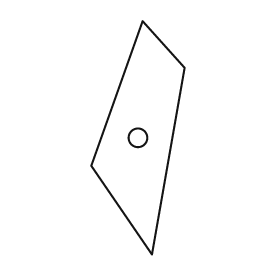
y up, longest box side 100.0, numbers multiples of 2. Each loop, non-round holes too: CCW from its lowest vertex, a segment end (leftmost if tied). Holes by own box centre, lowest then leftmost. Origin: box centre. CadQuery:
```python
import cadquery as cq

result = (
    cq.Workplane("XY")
    .moveTo(6.0, -50.0)
    .lineTo(20.0, 30.0)
    .lineTo(2.0, 50.0)
    .lineTo(-20.0, -12.0)
    .close()
    .moveTo(0.0, 0.0)
    .circle(4.0)
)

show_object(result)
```